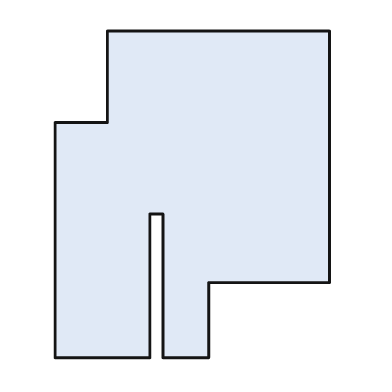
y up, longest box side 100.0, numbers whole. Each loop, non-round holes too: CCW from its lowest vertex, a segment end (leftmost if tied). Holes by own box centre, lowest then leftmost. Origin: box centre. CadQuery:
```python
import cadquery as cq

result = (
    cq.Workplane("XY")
    .moveTo(-42.0, -50.0)
    .lineTo(-13.0, -50.0)
    .lineTo(-13.0, -6.0)
    .lineTo(-9.0, -6.0)
    .lineTo(-9.0, -50.0)
    .lineTo(5.0, -50.0)
    .lineTo(5.0, -27.0)
    .lineTo(42.0, -27.0)
    .lineTo(42.0, 50.0)
    .lineTo(-26.0, 50.0)
    .lineTo(-26.0, 22.0)
    .lineTo(-42.0, 22.0)
    .close()
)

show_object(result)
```